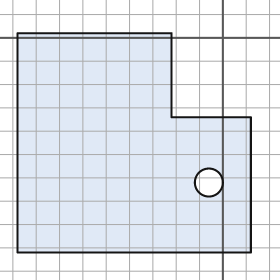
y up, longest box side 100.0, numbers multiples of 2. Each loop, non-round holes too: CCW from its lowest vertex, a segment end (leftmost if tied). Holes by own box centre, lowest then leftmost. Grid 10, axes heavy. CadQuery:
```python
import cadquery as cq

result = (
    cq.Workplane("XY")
    .moveTo(-88.0, -92.0)
    .lineTo(12.0, -92.0)
    .lineTo(12.0, -34.0)
    .lineTo(-22.0, -34.0)
    .lineTo(-22.0, 2.0)
    .lineTo(-88.0, 2.0)
    .close()
    .moveTo(-6.0, -62.0)
    .circle(6.0)
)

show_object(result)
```